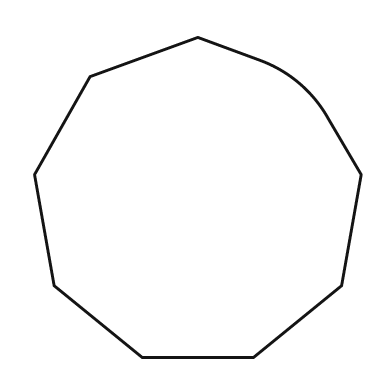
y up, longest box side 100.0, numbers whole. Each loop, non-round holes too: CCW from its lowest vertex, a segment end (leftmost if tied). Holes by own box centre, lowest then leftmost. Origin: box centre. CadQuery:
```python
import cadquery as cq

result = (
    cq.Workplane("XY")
    .moveTo(-17.0, -49.0)
    .lineTo(17.0, -49.0)
    .lineTo(44.0, -27.0)
    .lineTo(50.0, 7.0)
    .lineTo(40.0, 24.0)
    .threePointArc((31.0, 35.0), (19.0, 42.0))
    .lineTo(0.0, 49.0)
    .lineTo(-33.0, 37.0)
    .lineTo(-50.0, 7.0)
    .lineTo(-44.0, -27.0)
    .close()
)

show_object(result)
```